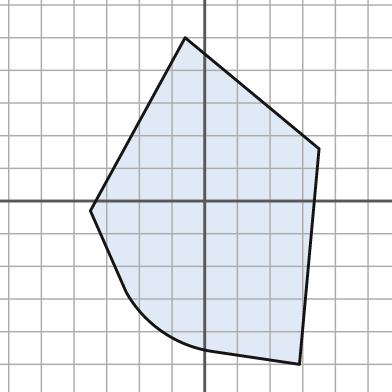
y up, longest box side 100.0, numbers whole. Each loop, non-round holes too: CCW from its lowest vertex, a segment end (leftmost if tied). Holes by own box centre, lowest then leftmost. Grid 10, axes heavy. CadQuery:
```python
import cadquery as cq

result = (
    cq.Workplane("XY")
    .moveTo(29.0, -50.0)
    .lineTo(35.0, 16.0)
    .lineTo(-6.0, 50.0)
    .lineTo(-35.0, -3.0)
    .lineTo(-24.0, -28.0)
    .threePointArc((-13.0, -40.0), (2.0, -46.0))
    .close()
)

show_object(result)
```